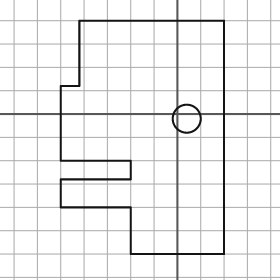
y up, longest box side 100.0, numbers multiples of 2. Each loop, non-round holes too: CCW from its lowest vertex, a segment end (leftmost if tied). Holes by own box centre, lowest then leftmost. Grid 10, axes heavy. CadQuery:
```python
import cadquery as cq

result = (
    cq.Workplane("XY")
    .moveTo(-20.0, -60.0)
    .lineTo(20.0, -60.0)
    .lineTo(20.0, 40.0)
    .lineTo(-42.0, 40.0)
    .lineTo(-42.0, 12.0)
    .lineTo(-50.0, 12.0)
    .lineTo(-50.0, -20.0)
    .lineTo(-20.0, -20.0)
    .lineTo(-20.0, -28.0)
    .lineTo(-50.0, -28.0)
    .lineTo(-50.0, -40.0)
    .lineTo(-20.0, -40.0)
    .close()
    .moveTo(4.0, -2.0)
    .circle(6.0)
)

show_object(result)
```